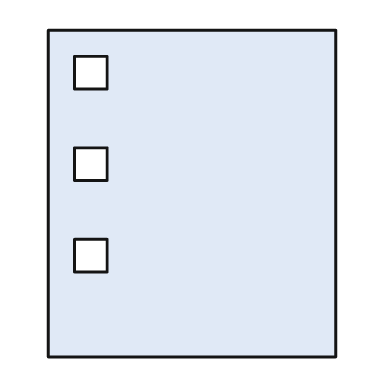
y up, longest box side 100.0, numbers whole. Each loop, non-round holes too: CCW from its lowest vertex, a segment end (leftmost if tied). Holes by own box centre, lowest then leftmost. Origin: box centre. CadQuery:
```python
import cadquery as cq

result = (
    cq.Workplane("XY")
    .moveTo(-44.0, -50.0)
    .lineTo(44.0, -50.0)
    .lineTo(44.0, 50.0)
    .lineTo(-44.0, 50.0)
    .close()
    .moveTo(-36.0, -24.0)
    .lineTo(-26.0, -24.0)
    .lineTo(-26.0, -14.0)
    .lineTo(-36.0, -14.0)
    .close()
    .moveTo(-36.0, 4.0)
    .lineTo(-26.0, 4.0)
    .lineTo(-26.0, 14.0)
    .lineTo(-36.0, 14.0)
    .close()
    .moveTo(-36.0, 32.0)
    .lineTo(-26.0, 32.0)
    .lineTo(-26.0, 42.0)
    .lineTo(-36.0, 42.0)
    .close()
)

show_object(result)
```